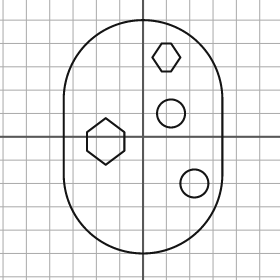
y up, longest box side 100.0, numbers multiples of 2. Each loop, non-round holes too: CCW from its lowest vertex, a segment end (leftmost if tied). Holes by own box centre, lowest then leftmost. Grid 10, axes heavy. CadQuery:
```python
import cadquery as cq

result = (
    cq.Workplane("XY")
    .moveTo(-34.0, -16.0)
    .threePointArc((0.0, -50.0), (34.0, -16.0))
    .lineTo(34.0, 16.0)
    .threePointArc((0.0, 50.0), (-34.0, 16.0))
    .close()
    .moveTo(22.0, -20.0)
    .circle(6.0)
    .moveTo(-16.0, -12.0)
    .lineTo(-8.0, -6.0)
    .lineTo(-8.0, 2.0)
    .lineTo(-16.0, 8.0)
    .lineTo(-24.0, 2.0)
    .lineTo(-24.0, -6.0)
    .close()
    .moveTo(12.0, 10.0)
    .circle(6.0)
    .moveTo(8.0, 28.0)
    .lineTo(12.0, 28.0)
    .lineTo(16.0, 34.0)
    .lineTo(12.0, 40.0)
    .lineTo(8.0, 40.0)
    .lineTo(4.0, 34.0)
    .close()
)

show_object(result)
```